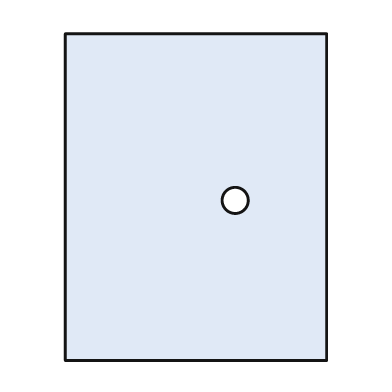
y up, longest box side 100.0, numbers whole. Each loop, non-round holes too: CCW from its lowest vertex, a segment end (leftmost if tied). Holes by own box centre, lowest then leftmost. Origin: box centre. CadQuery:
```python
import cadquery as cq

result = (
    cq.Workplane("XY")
    .moveTo(-40.0, -50.0)
    .lineTo(40.0, -50.0)
    .lineTo(40.0, 50.0)
    .lineTo(-40.0, 50.0)
    .close()
    .moveTo(12.0, -1.0)
    .circle(4.0)
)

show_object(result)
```